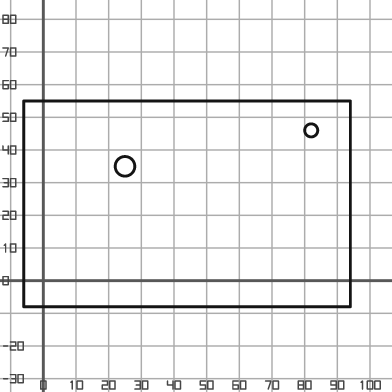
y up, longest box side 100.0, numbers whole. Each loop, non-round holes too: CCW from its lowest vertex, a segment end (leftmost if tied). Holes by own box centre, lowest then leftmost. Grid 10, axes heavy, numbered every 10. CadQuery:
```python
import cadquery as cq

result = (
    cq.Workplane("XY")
    .moveTo(-6.0, -8.0)
    .lineTo(94.0, -8.0)
    .lineTo(94.0, 55.0)
    .lineTo(-6.0, 55.0)
    .close()
    .moveTo(25.0, 35.0)
    .circle(3.0)
    .moveTo(82.0, 46.0)
    .circle(2.0)
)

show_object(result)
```